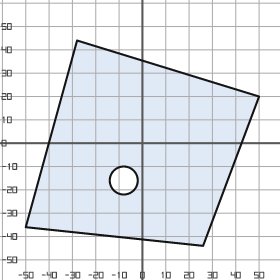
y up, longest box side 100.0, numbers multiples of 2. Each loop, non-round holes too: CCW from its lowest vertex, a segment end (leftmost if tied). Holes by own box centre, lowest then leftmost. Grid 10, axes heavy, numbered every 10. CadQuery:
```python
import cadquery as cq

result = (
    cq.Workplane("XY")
    .moveTo(26.0, -44.0)
    .lineTo(50.0, 20.0)
    .lineTo(-28.0, 44.0)
    .lineTo(-50.0, -36.0)
    .close()
    .moveTo(-8.0, -16.0)
    .circle(6.0)
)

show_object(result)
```